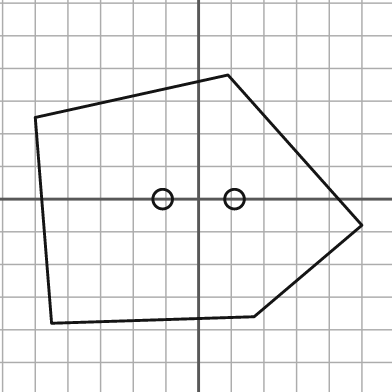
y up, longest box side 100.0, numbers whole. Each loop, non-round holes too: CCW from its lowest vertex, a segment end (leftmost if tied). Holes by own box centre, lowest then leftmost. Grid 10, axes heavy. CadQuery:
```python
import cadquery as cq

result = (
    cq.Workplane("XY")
    .moveTo(-45.0, -38.0)
    .lineTo(17.0, -36.0)
    .lineTo(50.0, -8.0)
    .lineTo(9.0, 38.0)
    .lineTo(-50.0, 25.0)
    .close()
    .moveTo(-11.0, 0.0)
    .circle(3.0)
    .moveTo(11.0, 0.0)
    .circle(3.0)
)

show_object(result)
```